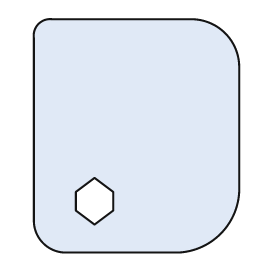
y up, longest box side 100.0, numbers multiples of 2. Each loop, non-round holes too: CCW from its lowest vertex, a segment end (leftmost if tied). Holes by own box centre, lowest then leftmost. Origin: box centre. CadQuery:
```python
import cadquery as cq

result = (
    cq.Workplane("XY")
    .moveTo(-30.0, -50.0)
    .lineTo(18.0, -50.0)
    .threePointArc((36.0, -42.0), (44.0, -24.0))
    .lineTo(44.0, 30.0)
    .threePointArc((38.0, 44.0), (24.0, 50.0))
    .lineTo(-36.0, 50.0)
    .threePointArc((-42.0, 48.0), (-44.0, 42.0))
    .lineTo(-44.0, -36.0)
    .threePointArc((-40.0, -46.0), (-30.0, -50.0))
    .close()
    .moveTo(-18.0, -38.0)
    .lineTo(-10.0, -32.0)
    .lineTo(-10.0, -24.0)
    .lineTo(-18.0, -18.0)
    .lineTo(-26.0, -24.0)
    .lineTo(-26.0, -32.0)
    .close()
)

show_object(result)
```